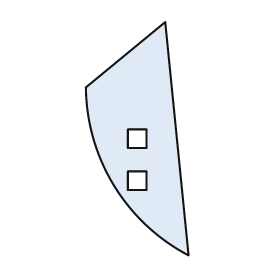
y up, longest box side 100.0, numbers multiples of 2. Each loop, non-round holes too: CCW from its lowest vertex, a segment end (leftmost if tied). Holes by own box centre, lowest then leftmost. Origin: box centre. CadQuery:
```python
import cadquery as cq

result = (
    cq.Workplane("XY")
    .moveTo(22.0, -50.0)
    .lineTo(12.0, 50.0)
    .lineTo(-22.0, 22.0)
    .threePointArc((-10.0, -20.0), (22.0, -50.0))
    .close()
    .moveTo(-4.0, -22.0)
    .lineTo(4.0, -22.0)
    .lineTo(4.0, -14.0)
    .lineTo(-4.0, -14.0)
    .close()
    .moveTo(-4.0, -4.0)
    .lineTo(4.0, -4.0)
    .lineTo(4.0, 4.0)
    .lineTo(-4.0, 4.0)
    .close()
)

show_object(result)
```